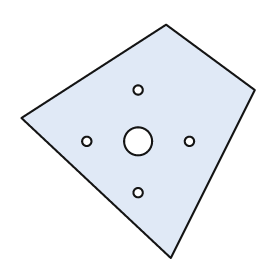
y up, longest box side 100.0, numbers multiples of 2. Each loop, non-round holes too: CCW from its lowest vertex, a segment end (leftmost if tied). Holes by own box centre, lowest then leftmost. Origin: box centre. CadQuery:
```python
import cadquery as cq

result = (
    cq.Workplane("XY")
    .moveTo(14.0, -50.0)
    .lineTo(50.0, 22.0)
    .lineTo(12.0, 50.0)
    .lineTo(-50.0, 10.0)
    .close()
    .moveTo(0.0, -22.0)
    .circle(2.0)
    .moveTo(-22.0, 0.0)
    .circle(2.0)
    .moveTo(0.0, 0.0)
    .circle(6.0)
    .moveTo(22.0, 0.0)
    .circle(2.0)
    .moveTo(0.0, 22.0)
    .circle(2.0)
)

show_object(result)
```